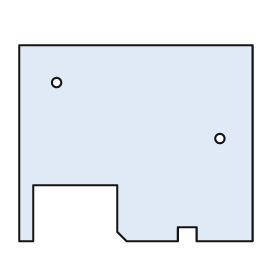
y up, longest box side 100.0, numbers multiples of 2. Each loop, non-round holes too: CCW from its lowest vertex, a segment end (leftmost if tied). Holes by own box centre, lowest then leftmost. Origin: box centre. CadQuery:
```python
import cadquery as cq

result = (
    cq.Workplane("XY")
    .moveTo(-50.0, -42.0)
    .lineTo(-44.0, -42.0)
    .lineTo(-44.0, -18.0)
    .lineTo(-8.0, -18.0)
    .lineTo(-8.0, -38.0)
    .lineTo(-4.0, -42.0)
    .lineTo(18.0, -42.0)
    .lineTo(18.0, -36.0)
    .lineTo(26.0, -36.0)
    .lineTo(26.0, -42.0)
    .lineTo(50.0, -42.0)
    .lineTo(50.0, 42.0)
    .lineTo(-50.0, 42.0)
    .close()
    .moveTo(36.0, 2.0)
    .circle(2.0)
    .moveTo(-34.0, 26.0)
    .circle(2.0)
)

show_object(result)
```